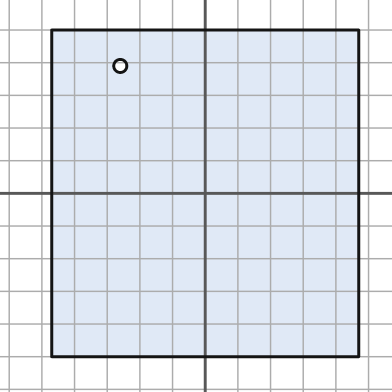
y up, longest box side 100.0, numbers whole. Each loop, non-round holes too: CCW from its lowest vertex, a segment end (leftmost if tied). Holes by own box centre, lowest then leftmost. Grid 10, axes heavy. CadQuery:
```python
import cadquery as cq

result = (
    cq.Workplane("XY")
    .moveTo(-47.0, -50.0)
    .lineTo(47.0, -50.0)
    .lineTo(47.0, 50.0)
    .lineTo(-47.0, 50.0)
    .close()
    .moveTo(-26.0, 39.0)
    .circle(2.0)
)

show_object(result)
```